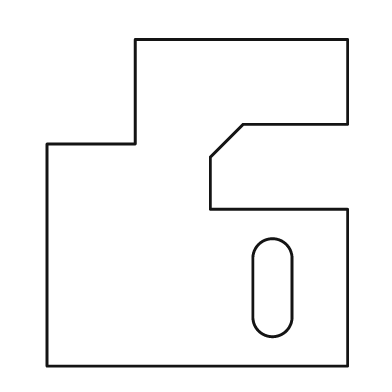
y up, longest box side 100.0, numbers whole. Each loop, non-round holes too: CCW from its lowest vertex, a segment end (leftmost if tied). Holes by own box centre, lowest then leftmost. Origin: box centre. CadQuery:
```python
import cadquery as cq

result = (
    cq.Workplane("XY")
    .moveTo(-46.0, -50.0)
    .lineTo(46.0, -50.0)
    .lineTo(46.0, -2.0)
    .lineTo(4.0, -2.0)
    .lineTo(4.0, 14.0)
    .lineTo(14.0, 24.0)
    .lineTo(46.0, 24.0)
    .lineTo(46.0, 50.0)
    .lineTo(-19.0, 50.0)
    .lineTo(-19.0, 18.0)
    .lineTo(-46.0, 18.0)
    .close()
    .moveTo(17.0, -35.0)
    .threePointArc((23.0, -41.0), (29.0, -35.0))
    .lineTo(29.0, -17.0)
    .threePointArc((23.0, -11.0), (17.0, -17.0))
    .close()
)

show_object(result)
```